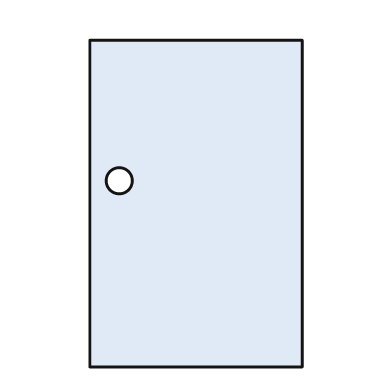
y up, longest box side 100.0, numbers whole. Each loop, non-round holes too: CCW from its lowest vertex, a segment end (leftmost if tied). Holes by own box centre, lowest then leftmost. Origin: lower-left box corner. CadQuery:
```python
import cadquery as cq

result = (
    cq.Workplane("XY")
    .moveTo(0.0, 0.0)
    .lineTo(65.0, 0.0)
    .lineTo(65.0, 100.0)
    .lineTo(0.0, 100.0)
    .close()
    .moveTo(9.0, 57.0)
    .circle(4.0)
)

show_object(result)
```